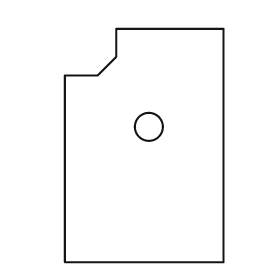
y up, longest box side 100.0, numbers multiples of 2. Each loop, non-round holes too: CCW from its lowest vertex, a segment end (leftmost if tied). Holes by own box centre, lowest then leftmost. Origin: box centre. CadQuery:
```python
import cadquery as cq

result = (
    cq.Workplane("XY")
    .moveTo(-34.0, -50.0)
    .lineTo(34.0, -50.0)
    .lineTo(34.0, 50.0)
    .lineTo(-12.0, 50.0)
    .lineTo(-12.0, 38.0)
    .lineTo(-20.0, 30.0)
    .lineTo(-34.0, 30.0)
    .close()
    .moveTo(2.0, 8.0)
    .circle(6.0)
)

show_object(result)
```